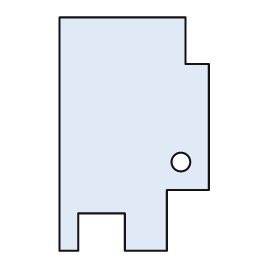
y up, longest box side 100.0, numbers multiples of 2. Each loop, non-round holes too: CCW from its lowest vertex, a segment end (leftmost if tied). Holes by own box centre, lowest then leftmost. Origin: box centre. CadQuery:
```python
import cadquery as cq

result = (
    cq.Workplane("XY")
    .moveTo(-32.0, -50.0)
    .lineTo(-24.0, -50.0)
    .lineTo(-24.0, -34.0)
    .lineTo(-4.0, -34.0)
    .lineTo(-4.0, -50.0)
    .lineTo(14.0, -50.0)
    .lineTo(14.0, -24.0)
    .lineTo(32.0, -24.0)
    .lineTo(32.0, 30.0)
    .lineTo(22.0, 30.0)
    .lineTo(22.0, 50.0)
    .lineTo(-32.0, 50.0)
    .close()
    .moveTo(20.0, -12.0)
    .circle(4.0)
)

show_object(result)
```